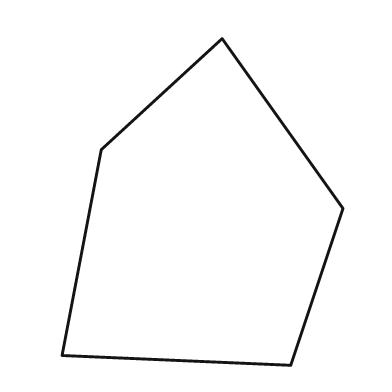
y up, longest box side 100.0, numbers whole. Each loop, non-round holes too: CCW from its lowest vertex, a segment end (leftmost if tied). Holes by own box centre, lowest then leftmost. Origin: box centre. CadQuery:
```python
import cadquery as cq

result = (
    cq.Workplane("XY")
    .moveTo(27.0, -50.0)
    .lineTo(43.0, -2.0)
    .lineTo(6.0, 50.0)
    .lineTo(-31.0, 16.0)
    .lineTo(-43.0, -47.0)
    .close()
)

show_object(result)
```